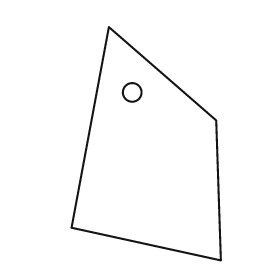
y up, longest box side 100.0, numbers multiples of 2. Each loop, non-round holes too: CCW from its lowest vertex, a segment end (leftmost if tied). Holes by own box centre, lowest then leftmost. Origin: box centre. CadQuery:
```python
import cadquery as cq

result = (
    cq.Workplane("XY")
    .moveTo(32.0, -50.0)
    .lineTo(30.0, 10.0)
    .lineTo(-16.0, 50.0)
    .lineTo(-32.0, -36.0)
    .close()
    .moveTo(-6.0, 22.0)
    .circle(4.0)
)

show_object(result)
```